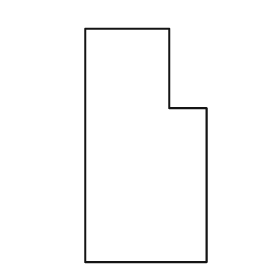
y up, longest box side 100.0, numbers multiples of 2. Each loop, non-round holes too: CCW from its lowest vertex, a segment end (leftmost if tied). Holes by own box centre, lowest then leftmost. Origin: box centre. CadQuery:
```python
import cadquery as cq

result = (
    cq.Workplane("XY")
    .moveTo(-26.0, -50.0)
    .lineTo(26.0, -50.0)
    .lineTo(26.0, 16.0)
    .lineTo(10.0, 16.0)
    .lineTo(10.0, 50.0)
    .lineTo(-26.0, 50.0)
    .close()
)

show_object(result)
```